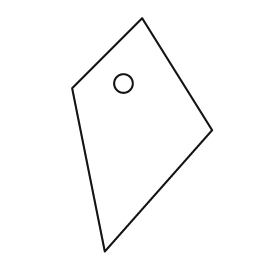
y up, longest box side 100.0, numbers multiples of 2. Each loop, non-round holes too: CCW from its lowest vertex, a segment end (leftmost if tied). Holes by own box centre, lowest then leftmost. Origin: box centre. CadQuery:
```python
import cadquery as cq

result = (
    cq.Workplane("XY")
    .moveTo(-16.0, -50.0)
    .lineTo(30.0, 2.0)
    .lineTo(0.0, 50.0)
    .lineTo(-30.0, 20.0)
    .close()
    .moveTo(-8.0, 22.0)
    .circle(4.0)
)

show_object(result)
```